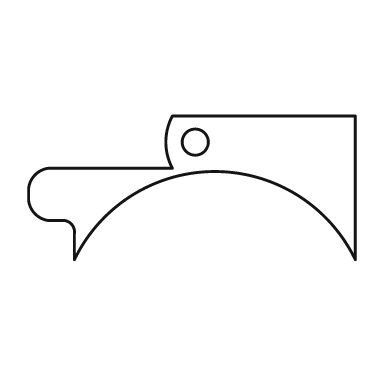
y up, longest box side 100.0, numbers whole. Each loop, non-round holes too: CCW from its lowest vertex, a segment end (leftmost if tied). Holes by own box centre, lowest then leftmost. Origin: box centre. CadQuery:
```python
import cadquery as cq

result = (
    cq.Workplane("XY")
    .moveTo(-36.0, -22.0)
    .threePointArc((7.0, 5.0), (50.0, -22.0))
    .lineTo(50.0, 22.0)
    .lineTo(-6.0, 22.0)
    .threePointArc((-8.0, 14.0), (-6.0, 6.0))
    .lineTo(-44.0, 6.0)
    .threePointArc((-48.0, 4.0), (-50.0, 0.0))
    .lineTo(-50.0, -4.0)
    .threePointArc((-48.0, -8.0), (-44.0, -10.0))
    .lineTo(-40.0, -10.0)
    .threePointArc((-37.0, -11.0), (-36.0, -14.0))
    .close()
    .moveTo(1.0, 14.0)
    .circle(4.0)
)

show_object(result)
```